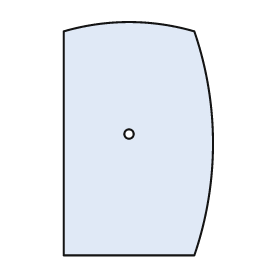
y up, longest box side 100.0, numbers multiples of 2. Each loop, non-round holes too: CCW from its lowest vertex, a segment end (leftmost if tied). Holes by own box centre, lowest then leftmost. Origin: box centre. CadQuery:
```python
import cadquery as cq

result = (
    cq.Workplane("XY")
    .moveTo(-32.0, -50.0)
    .lineTo(24.0, -50.0)
    .threePointArc((32.0, -2.0), (24.0, 46.0))
    .threePointArc((-4.0, 50.0), (-32.0, 46.0))
    .close()
    .moveTo(-4.0, 2.0)
    .circle(2.0)
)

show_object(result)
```